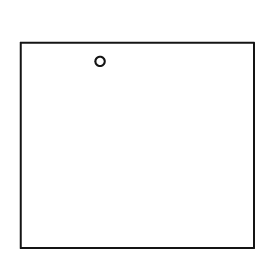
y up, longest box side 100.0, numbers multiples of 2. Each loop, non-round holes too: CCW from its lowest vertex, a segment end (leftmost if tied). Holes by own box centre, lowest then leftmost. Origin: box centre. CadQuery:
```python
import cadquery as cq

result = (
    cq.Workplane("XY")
    .moveTo(-50.0, -44.0)
    .lineTo(50.0, -44.0)
    .lineTo(50.0, 44.0)
    .lineTo(-50.0, 44.0)
    .close()
    .moveTo(-16.0, 36.0)
    .circle(2.0)
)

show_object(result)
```